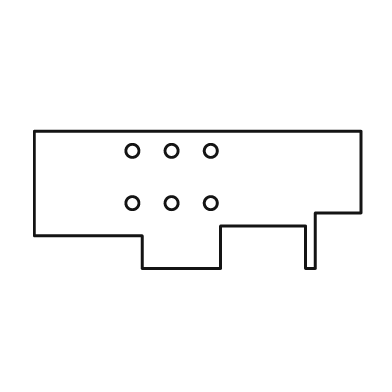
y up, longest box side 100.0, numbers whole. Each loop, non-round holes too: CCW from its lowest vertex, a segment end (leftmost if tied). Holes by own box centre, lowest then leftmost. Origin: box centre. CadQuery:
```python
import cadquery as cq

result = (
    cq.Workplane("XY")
    .moveTo(-17.0, -21.0)
    .lineTo(7.0, -21.0)
    .lineTo(7.0, -8.0)
    .lineTo(33.0, -8.0)
    .lineTo(33.0, -21.0)
    .lineTo(36.0, -21.0)
    .lineTo(36.0, -4.0)
    .lineTo(50.0, -4.0)
    .lineTo(50.0, 21.0)
    .lineTo(-50.0, 21.0)
    .lineTo(-50.0, -11.0)
    .lineTo(-17.0, -11.0)
    .close()
    .moveTo(-20.0, -1.0)
    .circle(2.0)
    .moveTo(-8.0, -1.0)
    .circle(2.0)
    .moveTo(4.0, -1.0)
    .circle(2.0)
    .moveTo(-20.0, 15.0)
    .circle(2.0)
    .moveTo(-8.0, 15.0)
    .circle(2.0)
    .moveTo(4.0, 15.0)
    .circle(2.0)
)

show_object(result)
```